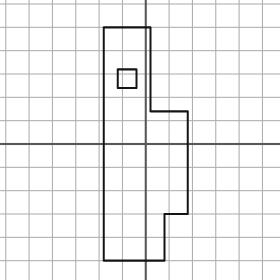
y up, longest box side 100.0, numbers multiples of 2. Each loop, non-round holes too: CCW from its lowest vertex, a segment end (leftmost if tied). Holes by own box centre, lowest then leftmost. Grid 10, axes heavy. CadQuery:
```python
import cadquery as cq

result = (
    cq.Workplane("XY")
    .moveTo(-18.0, -50.0)
    .lineTo(8.0, -50.0)
    .lineTo(8.0, -30.0)
    .lineTo(18.0, -30.0)
    .lineTo(18.0, 14.0)
    .lineTo(2.0, 14.0)
    .lineTo(2.0, 50.0)
    .lineTo(-18.0, 50.0)
    .close()
    .moveTo(-12.0, 24.0)
    .lineTo(-4.0, 24.0)
    .lineTo(-4.0, 32.0)
    .lineTo(-12.0, 32.0)
    .close()
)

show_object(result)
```